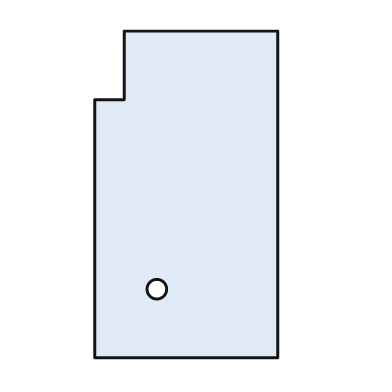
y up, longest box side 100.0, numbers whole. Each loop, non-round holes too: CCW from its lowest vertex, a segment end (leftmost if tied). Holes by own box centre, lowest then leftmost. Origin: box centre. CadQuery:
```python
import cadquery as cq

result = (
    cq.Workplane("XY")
    .moveTo(-28.0, -50.0)
    .lineTo(28.0, -50.0)
    .lineTo(28.0, 50.0)
    .lineTo(-19.0, 50.0)
    .lineTo(-19.0, 29.0)
    .lineTo(-28.0, 29.0)
    .close()
    .moveTo(-9.0, -29.0)
    .circle(3.0)
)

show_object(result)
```